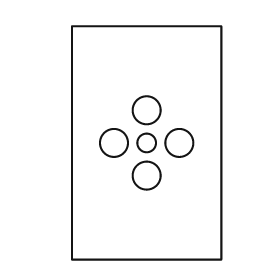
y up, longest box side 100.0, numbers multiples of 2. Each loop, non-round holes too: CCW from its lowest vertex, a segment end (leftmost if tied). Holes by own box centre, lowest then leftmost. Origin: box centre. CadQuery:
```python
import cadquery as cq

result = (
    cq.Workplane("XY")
    .moveTo(-32.0, -50.0)
    .lineTo(32.0, -50.0)
    .lineTo(32.0, 50.0)
    .lineTo(-32.0, 50.0)
    .close()
    .moveTo(0.0, -14.0)
    .circle(6.0)
    .moveTo(-14.0, 0.0)
    .circle(6.0)
    .moveTo(0.0, 0.0)
    .circle(4.0)
    .moveTo(14.0, 0.0)
    .circle(6.0)
    .moveTo(0.0, 14.0)
    .circle(6.0)
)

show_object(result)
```